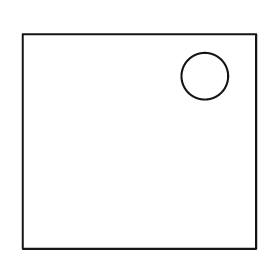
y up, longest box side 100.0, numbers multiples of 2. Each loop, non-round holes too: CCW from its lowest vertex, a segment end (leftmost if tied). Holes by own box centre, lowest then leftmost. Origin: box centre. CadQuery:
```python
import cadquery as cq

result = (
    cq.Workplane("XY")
    .moveTo(-50.0, -46.0)
    .lineTo(50.0, -46.0)
    .lineTo(50.0, 46.0)
    .lineTo(-50.0, 46.0)
    .close()
    .moveTo(28.0, 28.0)
    .circle(10.0)
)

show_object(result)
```